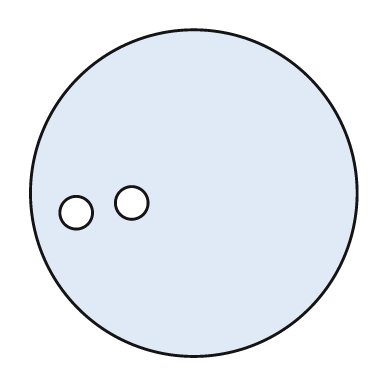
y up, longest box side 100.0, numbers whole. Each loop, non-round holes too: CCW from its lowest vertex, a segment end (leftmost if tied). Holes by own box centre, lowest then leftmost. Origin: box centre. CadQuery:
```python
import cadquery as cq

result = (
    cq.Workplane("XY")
    .moveTo(0.0, 0.0)
    .circle(50.0)
    .moveTo(-36.0, -6.0)
    .circle(5.0)
    .moveTo(-19.0, -3.0)
    .circle(5.0)
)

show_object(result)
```